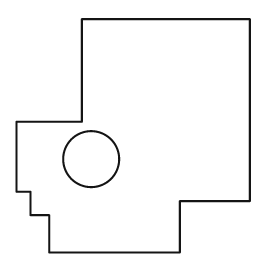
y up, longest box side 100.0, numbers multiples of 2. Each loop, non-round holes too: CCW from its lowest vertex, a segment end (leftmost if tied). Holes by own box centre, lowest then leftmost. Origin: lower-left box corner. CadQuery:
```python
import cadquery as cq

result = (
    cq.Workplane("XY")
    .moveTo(14.0, 0.0)
    .lineTo(70.0, 0.0)
    .lineTo(70.0, 22.0)
    .lineTo(100.0, 22.0)
    .lineTo(100.0, 100.0)
    .lineTo(28.0, 100.0)
    .lineTo(28.0, 56.0)
    .lineTo(0.0, 56.0)
    .lineTo(0.0, 26.0)
    .lineTo(6.0, 26.0)
    .lineTo(6.0, 16.0)
    .lineTo(14.0, 16.0)
    .close()
    .moveTo(32.0, 40.0)
    .circle(12.0)
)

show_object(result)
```